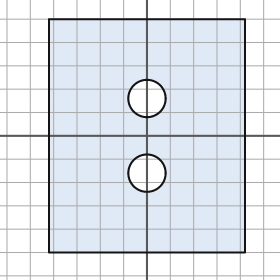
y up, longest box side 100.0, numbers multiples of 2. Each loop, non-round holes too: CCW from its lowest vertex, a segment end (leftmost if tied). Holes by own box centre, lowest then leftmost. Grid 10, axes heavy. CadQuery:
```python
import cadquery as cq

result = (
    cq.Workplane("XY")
    .moveTo(-42.0, -50.0)
    .lineTo(42.0, -50.0)
    .lineTo(42.0, 50.0)
    .lineTo(-42.0, 50.0)
    .close()
    .moveTo(0.0, -16.0)
    .circle(8.0)
    .moveTo(0.0, 16.0)
    .circle(8.0)
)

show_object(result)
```